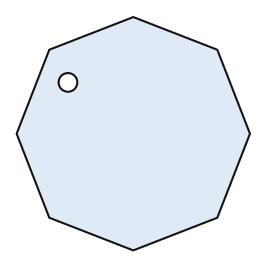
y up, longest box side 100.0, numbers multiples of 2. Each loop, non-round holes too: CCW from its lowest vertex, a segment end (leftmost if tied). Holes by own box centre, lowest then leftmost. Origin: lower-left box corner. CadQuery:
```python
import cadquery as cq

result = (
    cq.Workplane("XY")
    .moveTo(50.0, 0.0)
    .lineTo(86.0, 14.0)
    .lineTo(100.0, 50.0)
    .lineTo(86.0, 86.0)
    .lineTo(50.0, 100.0)
    .lineTo(14.0, 86.0)
    .lineTo(0.0, 50.0)
    .lineTo(14.0, 14.0)
    .close()
    .moveTo(22.0, 72.0)
    .circle(4.0)
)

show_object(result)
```